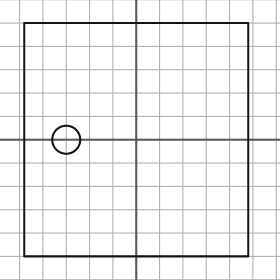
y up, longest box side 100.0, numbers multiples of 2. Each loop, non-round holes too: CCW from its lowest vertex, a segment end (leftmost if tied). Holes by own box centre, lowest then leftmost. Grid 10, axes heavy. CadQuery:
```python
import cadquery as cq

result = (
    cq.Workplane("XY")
    .moveTo(-48.0, -50.0)
    .lineTo(48.0, -50.0)
    .lineTo(48.0, 50.0)
    .lineTo(-48.0, 50.0)
    .close()
    .moveTo(-30.0, 0.0)
    .circle(6.0)
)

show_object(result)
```